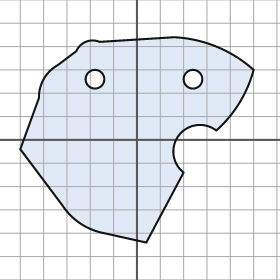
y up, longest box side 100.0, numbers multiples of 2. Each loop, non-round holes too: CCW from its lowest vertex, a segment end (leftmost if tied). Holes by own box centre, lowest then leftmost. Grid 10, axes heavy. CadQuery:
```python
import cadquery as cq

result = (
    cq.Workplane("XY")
    .moveTo(4.0, -44.0)
    .lineTo(20.0, -14.0)
    .threePointArc((18.0, 2.0), (34.0, 4.0))
    .threePointArc((44.0, 16.0), (50.0, 30.0))
    .threePointArc((34.0, 40.0), (16.0, 44.0))
    .lineTo(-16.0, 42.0)
    .threePointArc((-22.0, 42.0), (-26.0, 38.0))
    .lineTo(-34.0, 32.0)
    .threePointArc((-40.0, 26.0), (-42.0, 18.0))
    .lineTo(-50.0, -4.0)
    .lineTo(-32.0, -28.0)
    .threePointArc((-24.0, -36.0), (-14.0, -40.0))
    .close()
    .moveTo(-18.0, 26.0)
    .circle(4.0)
    .moveTo(24.0, 26.0)
    .circle(4.0)
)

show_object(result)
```